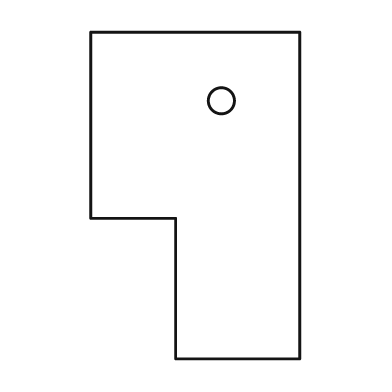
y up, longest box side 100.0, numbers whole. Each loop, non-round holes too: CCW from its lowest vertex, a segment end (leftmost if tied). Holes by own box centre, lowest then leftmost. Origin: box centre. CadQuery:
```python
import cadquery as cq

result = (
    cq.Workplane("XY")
    .moveTo(-6.0, -50.0)
    .lineTo(32.0, -50.0)
    .lineTo(32.0, 50.0)
    .lineTo(-32.0, 50.0)
    .lineTo(-32.0, -7.0)
    .lineTo(-6.0, -7.0)
    .close()
    .moveTo(8.0, 29.0)
    .circle(4.0)
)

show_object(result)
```